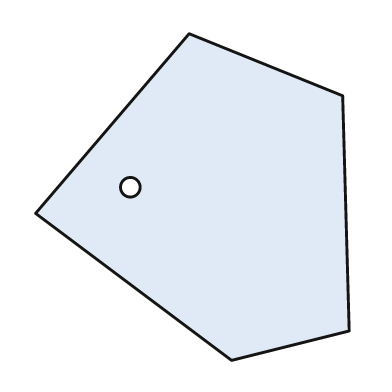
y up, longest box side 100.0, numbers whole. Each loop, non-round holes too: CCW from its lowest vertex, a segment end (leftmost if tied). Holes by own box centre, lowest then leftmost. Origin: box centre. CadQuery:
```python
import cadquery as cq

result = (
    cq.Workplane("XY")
    .moveTo(12.0, -50.0)
    .lineTo(48.0, -41.0)
    .lineTo(46.0, 31.0)
    .lineTo(-1.0, 50.0)
    .lineTo(-48.0, -5.0)
    .close()
    .moveTo(-19.0, 3.0)
    .circle(3.0)
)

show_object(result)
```